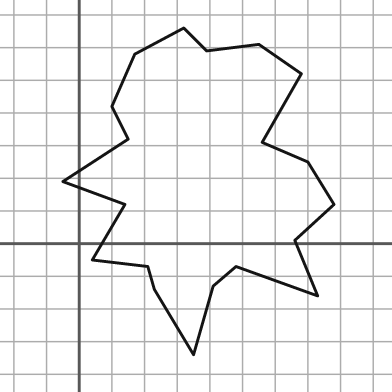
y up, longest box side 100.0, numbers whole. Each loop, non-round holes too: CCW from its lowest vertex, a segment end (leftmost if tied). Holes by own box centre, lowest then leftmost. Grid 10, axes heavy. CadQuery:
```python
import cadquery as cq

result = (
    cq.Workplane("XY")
    .moveTo(35.0, -34.0)
    .lineTo(41.0, -13.0)
    .lineTo(48.0, -7.0)
    .lineTo(73.0, -16.0)
    .lineTo(66.0, 1.0)
    .lineTo(78.0, 12.0)
    .lineTo(70.0, 25.0)
    .lineTo(56.0, 31.0)
    .lineTo(68.0, 52.0)
    .lineTo(55.0, 61.0)
    .lineTo(39.0, 59.0)
    .lineTo(32.0, 66.0)
    .lineTo(17.0, 58.0)
    .lineTo(10.0, 42.0)
    .lineTo(15.0, 32.0)
    .lineTo(-5.0, 19.0)
    .lineTo(14.0, 12.0)
    .lineTo(4.0, -5.0)
    .lineTo(21.0, -7.0)
    .lineTo(23.0, -14.0)
    .close()
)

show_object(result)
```